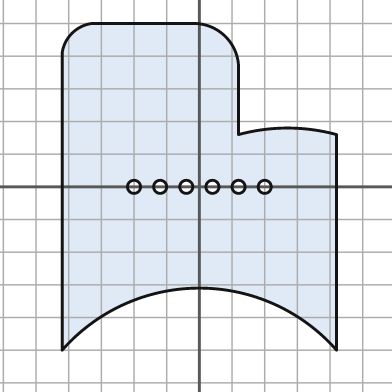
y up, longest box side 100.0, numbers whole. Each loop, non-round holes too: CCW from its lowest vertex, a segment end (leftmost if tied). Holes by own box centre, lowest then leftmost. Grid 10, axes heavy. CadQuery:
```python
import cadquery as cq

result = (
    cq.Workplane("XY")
    .moveTo(-42.0, -50.0)
    .threePointArc((0.0, -31.0), (42.0, -50.0))
    .lineTo(42.0, 16.0)
    .threePointArc((27.0, 18.0), (12.0, 16.0))
    .lineTo(12.0, 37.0)
    .threePointArc((8.0, 46.0), (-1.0, 50.0))
    .lineTo(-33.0, 50.0)
    .threePointArc((-39.0, 47.0), (-42.0, 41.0))
    .close()
    .moveTo(-20.0, 0.0)
    .circle(2.0)
    .moveTo(-12.0, 0.0)
    .circle(2.0)
    .moveTo(-4.0, 0.0)
    .circle(2.0)
    .moveTo(4.0, 0.0)
    .circle(2.0)
    .moveTo(12.0, 0.0)
    .circle(2.0)
    .moveTo(20.0, 0.0)
    .circle(2.0)
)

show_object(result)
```